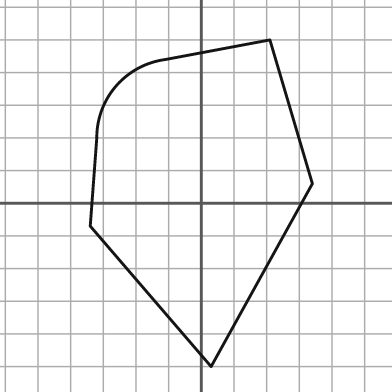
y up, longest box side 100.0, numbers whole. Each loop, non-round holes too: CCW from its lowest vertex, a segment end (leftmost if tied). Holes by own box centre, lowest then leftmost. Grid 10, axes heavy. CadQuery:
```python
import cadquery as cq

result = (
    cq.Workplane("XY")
    .moveTo(3.0, -50.0)
    .lineTo(34.0, 6.0)
    .lineTo(21.0, 50.0)
    .lineTo(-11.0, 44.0)
    .threePointArc((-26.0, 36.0), (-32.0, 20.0))
    .lineTo(-34.0, -7.0)
    .close()
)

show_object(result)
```